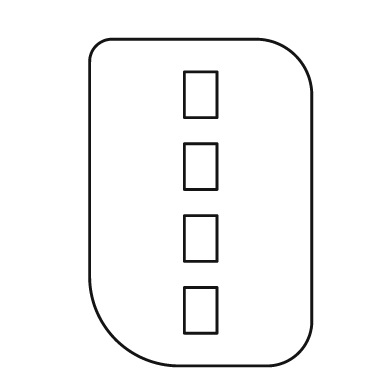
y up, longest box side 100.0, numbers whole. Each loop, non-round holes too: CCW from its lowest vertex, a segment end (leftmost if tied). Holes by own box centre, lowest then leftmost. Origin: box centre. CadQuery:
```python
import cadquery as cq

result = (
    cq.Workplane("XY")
    .moveTo(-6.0, -50.0)
    .lineTo(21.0, -50.0)
    .threePointArc((30.0, -46.0), (34.0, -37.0))
    .lineTo(34.0, 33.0)
    .threePointArc((29.0, 45.0), (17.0, 50.0))
    .lineTo(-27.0, 50.0)
    .threePointArc((-32.0, 48.0), (-34.0, 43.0))
    .lineTo(-34.0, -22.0)
    .threePointArc((-26.0, -42.0), (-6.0, -50.0))
    .close()
    .moveTo(-5.0, -40.0)
    .lineTo(5.0, -40.0)
    .lineTo(5.0, -26.0)
    .lineTo(-5.0, -26.0)
    .close()
    .moveTo(-5.0, -18.0)
    .lineTo(5.0, -18.0)
    .lineTo(5.0, -4.0)
    .lineTo(-5.0, -4.0)
    .close()
    .moveTo(-5.0, 4.0)
    .lineTo(5.0, 4.0)
    .lineTo(5.0, 18.0)
    .lineTo(-5.0, 18.0)
    .close()
    .moveTo(-5.0, 26.0)
    .lineTo(5.0, 26.0)
    .lineTo(5.0, 40.0)
    .lineTo(-5.0, 40.0)
    .close()
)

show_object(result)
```